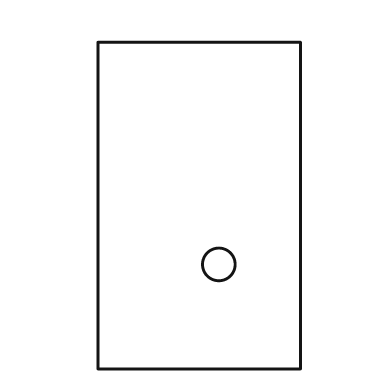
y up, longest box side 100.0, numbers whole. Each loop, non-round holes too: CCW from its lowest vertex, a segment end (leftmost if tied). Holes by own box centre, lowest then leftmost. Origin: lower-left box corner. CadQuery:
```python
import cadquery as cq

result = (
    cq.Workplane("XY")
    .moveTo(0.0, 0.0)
    .lineTo(62.0, 0.0)
    .lineTo(62.0, 100.0)
    .lineTo(0.0, 100.0)
    .close()
    .moveTo(37.0, 32.0)
    .circle(5.0)
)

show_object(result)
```